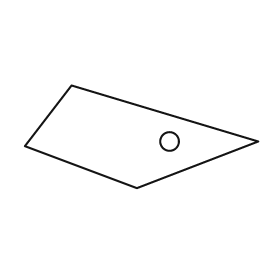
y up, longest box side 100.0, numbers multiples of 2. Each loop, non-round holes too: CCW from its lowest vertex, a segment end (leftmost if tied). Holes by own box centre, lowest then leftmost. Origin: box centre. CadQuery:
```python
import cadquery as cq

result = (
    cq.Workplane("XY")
    .moveTo(-2.0, -22.0)
    .lineTo(50.0, -2.0)
    .lineTo(-30.0, 22.0)
    .lineTo(-50.0, -4.0)
    .close()
    .moveTo(12.0, -2.0)
    .circle(4.0)
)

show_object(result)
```